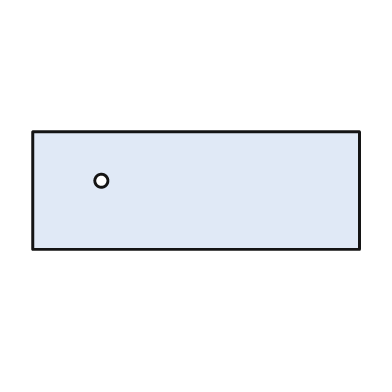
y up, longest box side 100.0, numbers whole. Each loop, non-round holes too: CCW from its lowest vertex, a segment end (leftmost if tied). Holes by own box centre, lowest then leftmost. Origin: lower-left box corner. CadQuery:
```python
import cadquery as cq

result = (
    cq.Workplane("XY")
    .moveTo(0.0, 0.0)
    .lineTo(100.0, 0.0)
    .lineTo(100.0, 36.0)
    .lineTo(0.0, 36.0)
    .close()
    .moveTo(21.0, 21.0)
    .circle(2.0)
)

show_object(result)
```